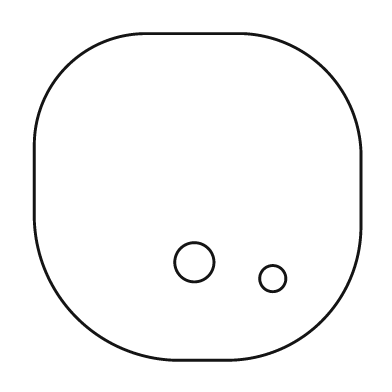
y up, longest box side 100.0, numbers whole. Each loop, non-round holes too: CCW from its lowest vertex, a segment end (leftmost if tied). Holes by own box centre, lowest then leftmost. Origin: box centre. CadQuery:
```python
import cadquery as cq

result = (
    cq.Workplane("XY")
    .moveTo(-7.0, -50.0)
    .lineTo(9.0, -50.0)
    .threePointArc((38.0, -38.0), (50.0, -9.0))
    .lineTo(50.0, 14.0)
    .threePointArc((39.0, 39.0), (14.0, 50.0))
    .lineTo(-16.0, 50.0)
    .threePointArc((-40.0, 40.0), (-50.0, 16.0))
    .lineTo(-50.0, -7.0)
    .threePointArc((-37.0, -37.0), (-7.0, -50.0))
    .close()
    .moveTo(23.0, -25.0)
    .circle(4.0)
    .moveTo(-1.0, -20.0)
    .circle(6.0)
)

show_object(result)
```